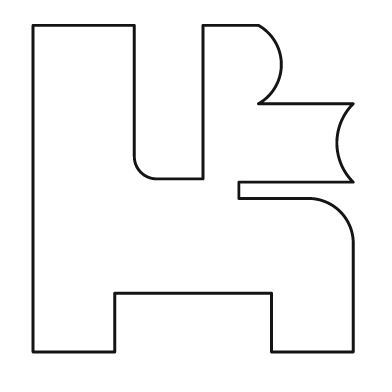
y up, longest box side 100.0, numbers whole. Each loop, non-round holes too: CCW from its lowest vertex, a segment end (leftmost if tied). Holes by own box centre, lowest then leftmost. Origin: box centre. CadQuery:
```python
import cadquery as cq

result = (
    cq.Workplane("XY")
    .moveTo(-49.0, -50.0)
    .lineTo(-24.0, -50.0)
    .lineTo(-24.0, -32.0)
    .lineTo(24.0, -32.0)
    .lineTo(24.0, -50.0)
    .lineTo(49.0, -50.0)
    .lineTo(49.0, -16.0)
    .threePointArc((45.0, -7.0), (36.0, -3.0))
    .lineTo(14.0, -3.0)
    .lineTo(14.0, 2.0)
    .lineTo(49.0, 2.0)
    .threePointArc((44.0, 14.0), (49.0, 26.0))
    .lineTo(20.0, 26.0)
    .threePointArc((27.0, 38.0), (20.0, 50.0))
    .lineTo(3.0, 50.0)
    .lineTo(3.0, 3.0)
    .lineTo(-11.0, 3.0)
    .threePointArc((-16.0, 5.0), (-18.0, 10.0))
    .lineTo(-18.0, 50.0)
    .lineTo(-49.0, 50.0)
    .close()
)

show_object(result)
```